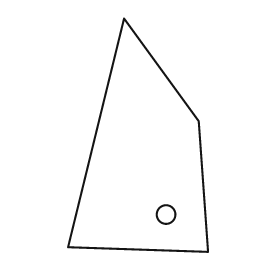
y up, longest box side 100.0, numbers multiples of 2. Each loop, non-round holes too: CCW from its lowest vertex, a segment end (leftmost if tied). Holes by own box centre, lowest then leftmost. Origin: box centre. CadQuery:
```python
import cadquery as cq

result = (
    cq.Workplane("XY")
    .moveTo(30.0, -50.0)
    .lineTo(26.0, 6.0)
    .lineTo(-6.0, 50.0)
    .lineTo(-30.0, -48.0)
    .close()
    .moveTo(12.0, -34.0)
    .circle(4.0)
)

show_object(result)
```